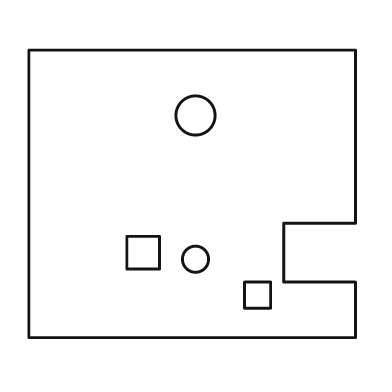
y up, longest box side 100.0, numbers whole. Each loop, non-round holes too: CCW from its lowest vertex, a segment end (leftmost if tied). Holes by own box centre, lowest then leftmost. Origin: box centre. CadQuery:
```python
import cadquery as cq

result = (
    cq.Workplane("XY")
    .moveTo(-50.0, -44.0)
    .lineTo(50.0, -44.0)
    .lineTo(50.0, -27.0)
    .lineTo(28.0, -27.0)
    .lineTo(28.0, -9.0)
    .lineTo(50.0, -9.0)
    .lineTo(50.0, 44.0)
    .lineTo(-50.0, 44.0)
    .close()
    .moveTo(16.0, -35.0)
    .lineTo(24.0, -35.0)
    .lineTo(24.0, -27.0)
    .lineTo(16.0, -27.0)
    .close()
    .moveTo(1.0, -20.0)
    .circle(4.0)
    .moveTo(-20.0, -23.0)
    .lineTo(-10.0, -23.0)
    .lineTo(-10.0, -13.0)
    .lineTo(-20.0, -13.0)
    .close()
    .moveTo(1.0, 24.0)
    .circle(6.0)
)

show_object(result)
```